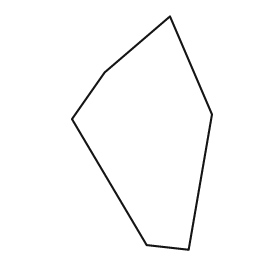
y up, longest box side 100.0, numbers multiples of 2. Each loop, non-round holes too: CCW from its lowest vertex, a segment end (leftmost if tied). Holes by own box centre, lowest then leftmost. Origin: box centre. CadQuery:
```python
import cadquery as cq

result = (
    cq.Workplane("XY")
    .moveTo(20.0, -50.0)
    .lineTo(30.0, 8.0)
    .lineTo(12.0, 50.0)
    .lineTo(-16.0, 26.0)
    .lineTo(-30.0, 6.0)
    .lineTo(2.0, -48.0)
    .close()
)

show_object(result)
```